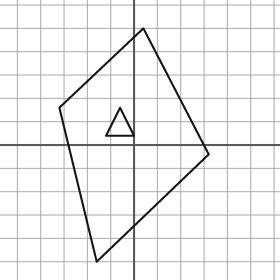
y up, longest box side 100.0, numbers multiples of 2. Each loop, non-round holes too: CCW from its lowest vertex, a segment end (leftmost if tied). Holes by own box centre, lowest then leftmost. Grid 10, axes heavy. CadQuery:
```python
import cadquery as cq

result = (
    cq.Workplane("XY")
    .moveTo(-16.0, -50.0)
    .lineTo(32.0, -4.0)
    .lineTo(4.0, 50.0)
    .lineTo(-32.0, 16.0)
    .close()
    .moveTo(-12.0, 4.0)
    .lineTo(0.0, 4.0)
    .lineTo(-6.0, 16.0)
    .close()
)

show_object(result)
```